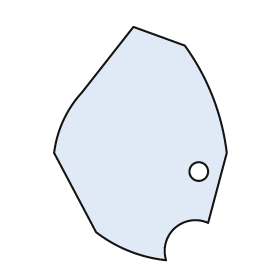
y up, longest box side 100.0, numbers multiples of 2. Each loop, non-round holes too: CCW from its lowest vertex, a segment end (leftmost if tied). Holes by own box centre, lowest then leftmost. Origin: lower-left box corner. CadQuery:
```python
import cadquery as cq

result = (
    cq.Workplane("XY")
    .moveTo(48.0, 0.0)
    .threePointArc((52.0, 14.0), (66.0, 16.0))
    .lineTo(74.0, 46.0)
    .threePointArc((68.0, 70.0), (56.0, 92.0))
    .lineTo(34.0, 100.0)
    .lineTo(12.0, 72.0)
    .threePointArc((4.0, 60.0), (0.0, 46.0))
    .lineTo(18.0, 12.0)
    .threePointArc((32.0, 4.0), (48.0, 0.0))
    .close()
    .moveTo(62.0, 38.0)
    .circle(4.0)
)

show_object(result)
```